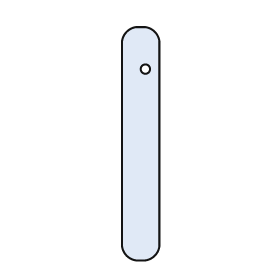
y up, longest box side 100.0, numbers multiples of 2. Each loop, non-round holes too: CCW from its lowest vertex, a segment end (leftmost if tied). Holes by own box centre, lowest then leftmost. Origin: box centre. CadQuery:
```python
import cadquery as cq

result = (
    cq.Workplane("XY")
    .moveTo(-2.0, -50.0)
    .lineTo(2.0, -50.0)
    .threePointArc((6.0, -48.0), (8.0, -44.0))
    .lineTo(8.0, 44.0)
    .threePointArc((6.0, 48.0), (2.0, 50.0))
    .lineTo(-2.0, 50.0)
    .threePointArc((-6.0, 48.0), (-8.0, 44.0))
    .lineTo(-8.0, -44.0)
    .threePointArc((-6.0, -48.0), (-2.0, -50.0))
    .close()
    .moveTo(2.0, 32.0)
    .circle(2.0)
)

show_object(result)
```